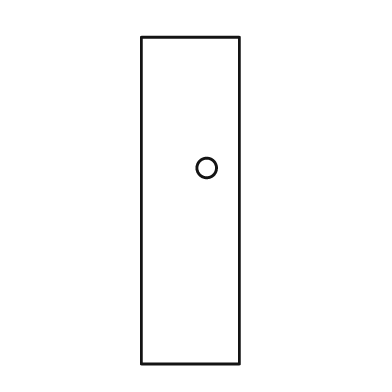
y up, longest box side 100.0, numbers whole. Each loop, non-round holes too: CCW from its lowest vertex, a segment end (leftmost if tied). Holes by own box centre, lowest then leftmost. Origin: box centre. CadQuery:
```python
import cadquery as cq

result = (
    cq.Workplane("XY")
    .moveTo(-15.0, -50.0)
    .lineTo(15.0, -50.0)
    .lineTo(15.0, 50.0)
    .lineTo(-15.0, 50.0)
    .close()
    .moveTo(5.0, 10.0)
    .circle(3.0)
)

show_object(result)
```